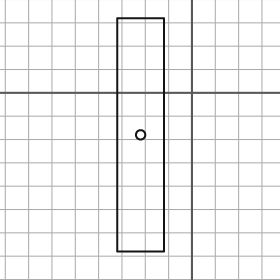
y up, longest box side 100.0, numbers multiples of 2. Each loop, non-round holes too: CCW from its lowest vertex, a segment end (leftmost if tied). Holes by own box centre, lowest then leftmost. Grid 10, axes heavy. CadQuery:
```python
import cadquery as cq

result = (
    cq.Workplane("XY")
    .moveTo(-32.0, -68.0)
    .lineTo(-12.0, -68.0)
    .lineTo(-12.0, 32.0)
    .lineTo(-32.0, 32.0)
    .close()
    .moveTo(-22.0, -18.0)
    .circle(2.0)
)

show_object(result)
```